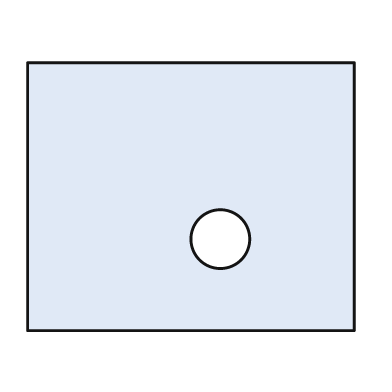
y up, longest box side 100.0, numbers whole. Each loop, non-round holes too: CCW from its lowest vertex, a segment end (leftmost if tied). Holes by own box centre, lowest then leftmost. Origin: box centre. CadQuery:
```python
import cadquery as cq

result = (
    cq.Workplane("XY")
    .moveTo(-50.0, -41.0)
    .lineTo(50.0, -41.0)
    .lineTo(50.0, 41.0)
    .lineTo(-50.0, 41.0)
    .close()
    .moveTo(9.0, -13.0)
    .circle(9.0)
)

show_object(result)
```